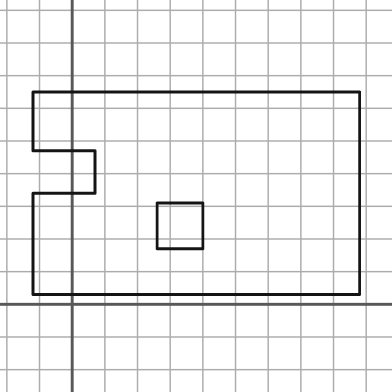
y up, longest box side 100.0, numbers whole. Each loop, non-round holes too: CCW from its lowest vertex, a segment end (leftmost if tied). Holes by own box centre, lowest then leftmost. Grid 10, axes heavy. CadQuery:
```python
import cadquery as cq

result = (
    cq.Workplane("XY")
    .moveTo(-12.0, 3.0)
    .lineTo(88.0, 3.0)
    .lineTo(88.0, 65.0)
    .lineTo(-12.0, 65.0)
    .lineTo(-12.0, 47.0)
    .lineTo(7.0, 47.0)
    .lineTo(7.0, 34.0)
    .lineTo(-12.0, 34.0)
    .close()
    .moveTo(26.0, 17.0)
    .lineTo(40.0, 17.0)
    .lineTo(40.0, 31.0)
    .lineTo(26.0, 31.0)
    .close()
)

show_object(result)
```